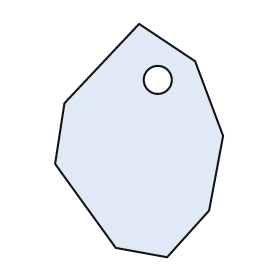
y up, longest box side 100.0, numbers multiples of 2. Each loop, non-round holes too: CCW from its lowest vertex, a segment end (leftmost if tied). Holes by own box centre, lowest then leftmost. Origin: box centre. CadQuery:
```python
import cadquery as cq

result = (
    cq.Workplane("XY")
    .moveTo(12.0, -50.0)
    .lineTo(30.0, -30.0)
    .lineTo(36.0, 2.0)
    .lineTo(24.0, 34.0)
    .lineTo(0.0, 50.0)
    .lineTo(-32.0, 16.0)
    .lineTo(-36.0, -10.0)
    .lineTo(-10.0, -46.0)
    .close()
    .moveTo(8.0, 26.0)
    .circle(6.0)
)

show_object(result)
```